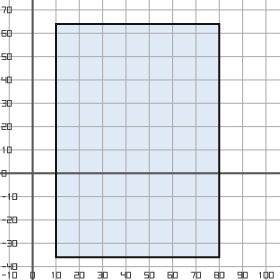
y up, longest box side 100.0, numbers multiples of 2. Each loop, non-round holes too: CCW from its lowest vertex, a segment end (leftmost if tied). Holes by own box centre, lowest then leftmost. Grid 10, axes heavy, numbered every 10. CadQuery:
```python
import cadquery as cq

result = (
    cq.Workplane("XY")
    .moveTo(10.0, -36.0)
    .lineTo(80.0, -36.0)
    .lineTo(80.0, 64.0)
    .lineTo(10.0, 64.0)
    .close()
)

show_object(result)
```